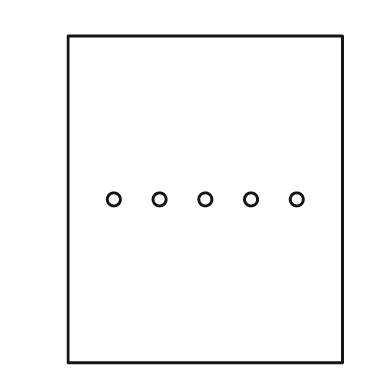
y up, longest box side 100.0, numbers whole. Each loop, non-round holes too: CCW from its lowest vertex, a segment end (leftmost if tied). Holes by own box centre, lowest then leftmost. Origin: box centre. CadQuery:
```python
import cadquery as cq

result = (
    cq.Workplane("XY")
    .moveTo(-42.0, -50.0)
    .lineTo(42.0, -50.0)
    .lineTo(42.0, 50.0)
    .lineTo(-42.0, 50.0)
    .close()
    .moveTo(-28.0, 0.0)
    .circle(2.0)
    .moveTo(-14.0, 0.0)
    .circle(2.0)
    .moveTo(0.0, 0.0)
    .circle(2.0)
    .moveTo(14.0, 0.0)
    .circle(2.0)
    .moveTo(28.0, 0.0)
    .circle(2.0)
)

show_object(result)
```